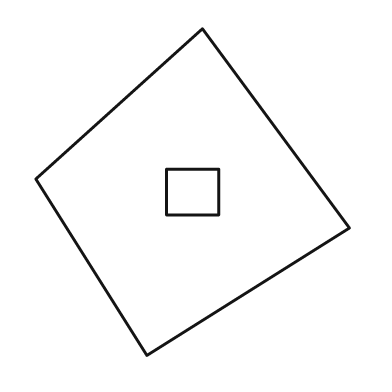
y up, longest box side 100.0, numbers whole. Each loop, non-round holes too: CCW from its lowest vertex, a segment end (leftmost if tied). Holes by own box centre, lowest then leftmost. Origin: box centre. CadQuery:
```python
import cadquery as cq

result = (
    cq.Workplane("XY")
    .moveTo(-14.0, -50.0)
    .lineTo(48.0, -11.0)
    .lineTo(3.0, 50.0)
    .lineTo(-48.0, 4.0)
    .close()
    .moveTo(-8.0, -7.0)
    .lineTo(8.0, -7.0)
    .lineTo(8.0, 7.0)
    .lineTo(-8.0, 7.0)
    .close()
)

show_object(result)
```